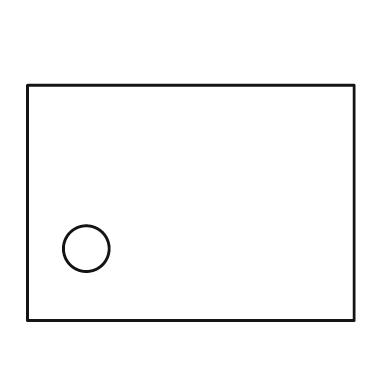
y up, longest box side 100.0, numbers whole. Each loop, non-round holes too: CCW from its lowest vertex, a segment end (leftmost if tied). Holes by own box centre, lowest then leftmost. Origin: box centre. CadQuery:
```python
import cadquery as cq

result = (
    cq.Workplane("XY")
    .moveTo(-50.0, -36.0)
    .lineTo(50.0, -36.0)
    .lineTo(50.0, 36.0)
    .lineTo(-50.0, 36.0)
    .close()
    .moveTo(-32.0, -14.0)
    .circle(7.0)
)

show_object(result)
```